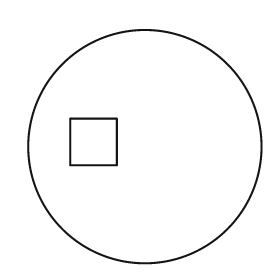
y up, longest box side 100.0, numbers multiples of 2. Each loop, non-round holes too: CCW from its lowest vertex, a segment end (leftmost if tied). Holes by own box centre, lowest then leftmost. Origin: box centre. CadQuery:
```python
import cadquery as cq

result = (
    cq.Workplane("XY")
    .moveTo(0.0, 0.0)
    .circle(50.0)
    .moveTo(-32.0, -8.0)
    .lineTo(-12.0, -8.0)
    .lineTo(-12.0, 12.0)
    .lineTo(-32.0, 12.0)
    .close()
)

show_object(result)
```